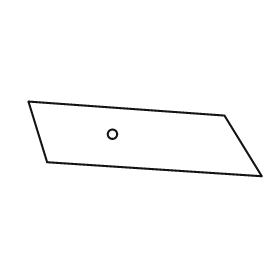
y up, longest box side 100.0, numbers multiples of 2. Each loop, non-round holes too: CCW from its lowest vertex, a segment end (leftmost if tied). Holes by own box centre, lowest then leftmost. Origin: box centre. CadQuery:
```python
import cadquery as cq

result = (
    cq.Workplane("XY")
    .moveTo(50.0, -16.0)
    .lineTo(34.0, 10.0)
    .lineTo(-50.0, 16.0)
    .lineTo(-42.0, -10.0)
    .close()
    .moveTo(-14.0, 2.0)
    .circle(2.0)
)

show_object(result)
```